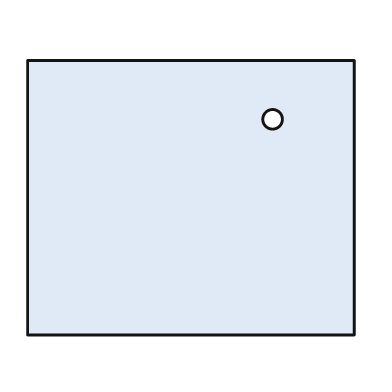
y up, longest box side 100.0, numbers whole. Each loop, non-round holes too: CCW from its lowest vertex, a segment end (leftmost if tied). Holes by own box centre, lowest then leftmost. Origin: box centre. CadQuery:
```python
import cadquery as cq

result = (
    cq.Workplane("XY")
    .moveTo(-50.0, -42.0)
    .lineTo(50.0, -42.0)
    .lineTo(50.0, 42.0)
    .lineTo(-50.0, 42.0)
    .close()
    .moveTo(25.0, 24.0)
    .circle(3.0)
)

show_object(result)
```